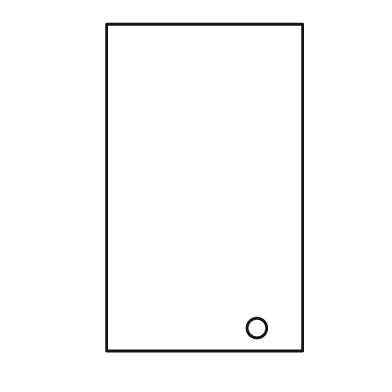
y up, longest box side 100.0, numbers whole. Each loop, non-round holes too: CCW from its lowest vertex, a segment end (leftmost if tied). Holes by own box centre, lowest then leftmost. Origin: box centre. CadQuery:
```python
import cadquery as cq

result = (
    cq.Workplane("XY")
    .moveTo(-30.0, -50.0)
    .lineTo(30.0, -50.0)
    .lineTo(30.0, 50.0)
    .lineTo(-30.0, 50.0)
    .close()
    .moveTo(16.0, -43.0)
    .circle(3.0)
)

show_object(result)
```